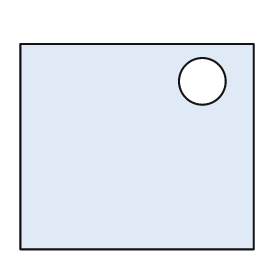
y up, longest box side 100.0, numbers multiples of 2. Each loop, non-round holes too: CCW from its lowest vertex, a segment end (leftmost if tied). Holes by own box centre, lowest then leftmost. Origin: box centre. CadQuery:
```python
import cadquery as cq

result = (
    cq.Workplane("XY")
    .moveTo(-50.0, -44.0)
    .lineTo(50.0, -44.0)
    .lineTo(50.0, 44.0)
    .lineTo(-50.0, 44.0)
    .close()
    .moveTo(28.0, 28.0)
    .circle(10.0)
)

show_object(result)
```